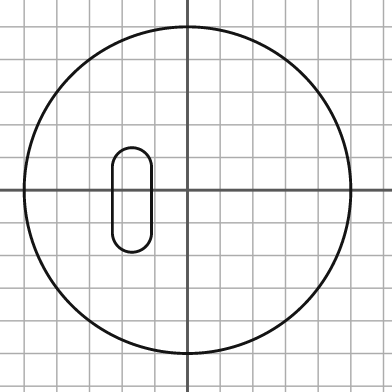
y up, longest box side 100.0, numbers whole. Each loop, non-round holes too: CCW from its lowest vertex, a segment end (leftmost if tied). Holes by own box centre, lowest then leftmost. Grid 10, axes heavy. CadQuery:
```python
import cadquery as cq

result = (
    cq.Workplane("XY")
    .moveTo(0.0, 0.0)
    .circle(50.0)
    .moveTo(-23.0, -13.0)
    .threePointArc((-17.0, -19.0), (-11.0, -13.0))
    .lineTo(-11.0, 7.0)
    .threePointArc((-17.0, 13.0), (-23.0, 7.0))
    .close()
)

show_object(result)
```